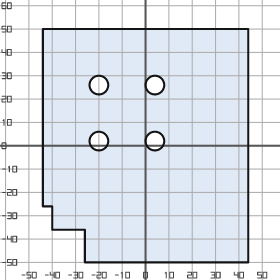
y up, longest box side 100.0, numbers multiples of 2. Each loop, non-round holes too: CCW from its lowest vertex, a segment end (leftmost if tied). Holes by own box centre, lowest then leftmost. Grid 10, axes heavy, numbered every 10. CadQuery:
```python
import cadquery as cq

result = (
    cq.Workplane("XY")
    .moveTo(-26.0, -50.0)
    .lineTo(44.0, -50.0)
    .lineTo(44.0, 50.0)
    .lineTo(-44.0, 50.0)
    .lineTo(-44.0, -26.0)
    .lineTo(-40.0, -26.0)
    .lineTo(-40.0, -36.0)
    .lineTo(-26.0, -36.0)
    .close()
    .moveTo(-20.0, 2.0)
    .circle(4.0)
    .moveTo(4.0, 2.0)
    .circle(4.0)
    .moveTo(-20.0, 26.0)
    .circle(4.0)
    .moveTo(4.0, 26.0)
    .circle(4.0)
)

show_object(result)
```